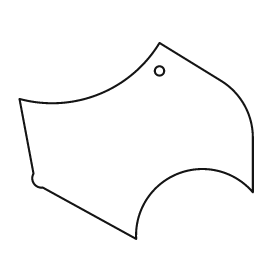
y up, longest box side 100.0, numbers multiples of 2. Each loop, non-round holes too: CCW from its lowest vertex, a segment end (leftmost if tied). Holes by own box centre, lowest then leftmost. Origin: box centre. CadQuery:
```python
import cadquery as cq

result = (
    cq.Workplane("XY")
    .moveTo(0.0, -42.0)
    .threePointArc((18.0, -14.0), (50.0, -22.0))
    .lineTo(50.0, 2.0)
    .threePointArc((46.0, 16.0), (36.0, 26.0))
    .lineTo(10.0, 42.0)
    .threePointArc((-16.0, 20.0), (-50.0, 18.0))
    .lineTo(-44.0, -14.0)
    .threePointArc((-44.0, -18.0), (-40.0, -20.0))
    .close()
    .moveTo(10.0, 30.0)
    .circle(2.0)
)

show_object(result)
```